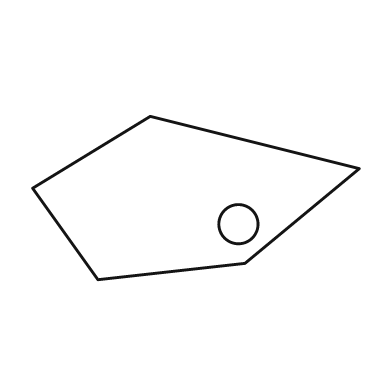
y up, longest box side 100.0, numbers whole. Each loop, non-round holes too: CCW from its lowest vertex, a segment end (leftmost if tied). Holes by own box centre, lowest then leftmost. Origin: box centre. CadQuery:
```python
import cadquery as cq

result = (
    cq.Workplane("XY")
    .moveTo(-30.0, -25.0)
    .lineTo(15.0, -20.0)
    .lineTo(50.0, 9.0)
    .lineTo(-14.0, 25.0)
    .lineTo(-50.0, 3.0)
    .close()
    .moveTo(13.0, -8.0)
    .circle(6.0)
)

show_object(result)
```